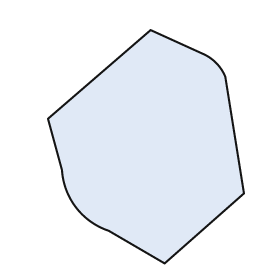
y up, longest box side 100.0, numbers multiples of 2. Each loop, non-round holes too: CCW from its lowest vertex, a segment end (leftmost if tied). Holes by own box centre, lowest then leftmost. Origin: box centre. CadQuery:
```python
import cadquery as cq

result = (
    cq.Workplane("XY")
    .moveTo(8.0, -50.0)
    .lineTo(42.0, -20.0)
    .lineTo(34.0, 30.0)
    .threePointArc((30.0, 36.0), (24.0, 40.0))
    .lineTo(2.0, 50.0)
    .lineTo(-42.0, 12.0)
    .lineTo(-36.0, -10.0)
    .threePointArc((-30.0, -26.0), (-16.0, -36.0))
    .close()
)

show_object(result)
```